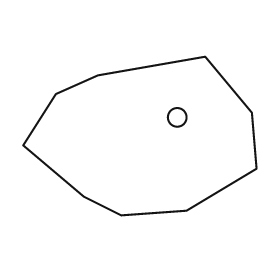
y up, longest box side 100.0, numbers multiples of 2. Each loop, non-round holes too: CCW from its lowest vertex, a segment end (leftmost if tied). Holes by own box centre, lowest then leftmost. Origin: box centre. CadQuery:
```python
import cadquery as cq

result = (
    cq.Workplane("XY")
    .moveTo(-8.0, -34.0)
    .lineTo(20.0, -32.0)
    .lineTo(50.0, -14.0)
    .lineTo(48.0, 10.0)
    .lineTo(28.0, 34.0)
    .lineTo(-18.0, 26.0)
    .lineTo(-36.0, 18.0)
    .lineTo(-50.0, -4.0)
    .lineTo(-24.0, -26.0)
    .close()
    .moveTo(16.0, 8.0)
    .circle(4.0)
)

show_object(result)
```